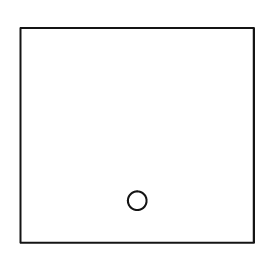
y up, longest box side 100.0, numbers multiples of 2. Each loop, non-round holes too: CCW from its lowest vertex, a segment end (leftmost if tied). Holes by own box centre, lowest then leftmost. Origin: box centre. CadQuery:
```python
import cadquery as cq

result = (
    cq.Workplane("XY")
    .moveTo(-50.0, -46.0)
    .lineTo(50.0, -46.0)
    .lineTo(50.0, 46.0)
    .lineTo(-50.0, 46.0)
    .close()
    .moveTo(0.0, -28.0)
    .circle(4.0)
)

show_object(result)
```